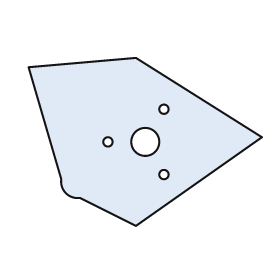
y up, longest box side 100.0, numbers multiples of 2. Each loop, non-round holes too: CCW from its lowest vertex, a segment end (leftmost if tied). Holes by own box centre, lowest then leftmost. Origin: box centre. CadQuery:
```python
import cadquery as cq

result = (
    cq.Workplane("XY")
    .moveTo(-4.0, -36.0)
    .lineTo(50.0, 2.0)
    .lineTo(-4.0, 36.0)
    .lineTo(-50.0, 32.0)
    .lineTo(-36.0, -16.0)
    .threePointArc((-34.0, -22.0), (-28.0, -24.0))
    .close()
    .moveTo(8.0, -14.0)
    .circle(2.0)
    .moveTo(-16.0, 0.0)
    .circle(2.0)
    .moveTo(0.0, 0.0)
    .circle(6.0)
    .moveTo(8.0, 14.0)
    .circle(2.0)
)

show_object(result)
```